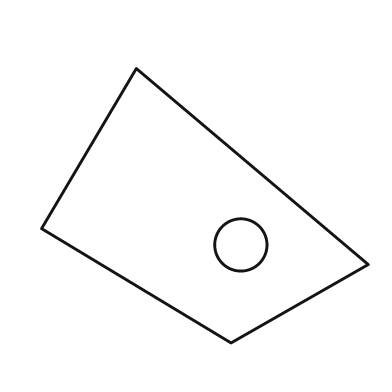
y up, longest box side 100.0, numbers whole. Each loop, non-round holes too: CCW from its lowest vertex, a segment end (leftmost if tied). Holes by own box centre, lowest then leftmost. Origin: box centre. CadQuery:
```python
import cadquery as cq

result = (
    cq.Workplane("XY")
    .moveTo(8.0, -42.0)
    .lineTo(50.0, -18.0)
    .lineTo(-21.0, 42.0)
    .lineTo(-50.0, -7.0)
    .close()
    .moveTo(11.0, -12.0)
    .circle(8.0)
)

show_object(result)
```